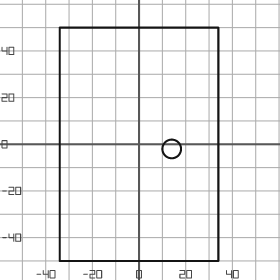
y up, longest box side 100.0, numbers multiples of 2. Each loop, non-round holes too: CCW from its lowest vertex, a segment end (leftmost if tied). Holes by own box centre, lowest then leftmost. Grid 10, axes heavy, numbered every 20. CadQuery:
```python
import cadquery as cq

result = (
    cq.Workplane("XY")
    .moveTo(-34.0, -50.0)
    .lineTo(34.0, -50.0)
    .lineTo(34.0, 50.0)
    .lineTo(-34.0, 50.0)
    .close()
    .moveTo(14.0, -2.0)
    .circle(4.0)
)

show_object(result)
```